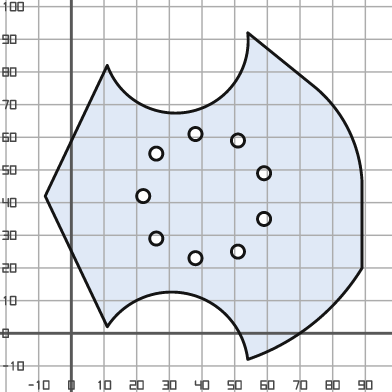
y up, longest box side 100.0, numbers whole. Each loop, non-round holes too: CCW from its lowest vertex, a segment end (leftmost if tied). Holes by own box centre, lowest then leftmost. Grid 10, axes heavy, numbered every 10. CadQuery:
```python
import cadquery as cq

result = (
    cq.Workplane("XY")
    .moveTo(54.0, -8.0)
    .threePointArc((74.0, 3.0), (89.0, 20.0))
    .lineTo(89.0, 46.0)
    .threePointArc((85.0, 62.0), (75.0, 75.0))
    .lineTo(54.0, 92.0)
    .threePointArc((37.0, 68.0), (11.0, 82.0))
    .lineTo(-8.0, 42.0)
    .lineTo(11.0, 2.0)
    .threePointArc((36.0, 12.0), (54.0, -8.0))
    .close()
    .moveTo(38.0, 23.0)
    .circle(2.0)
    .moveTo(51.0, 25.0)
    .circle(2.0)
    .moveTo(26.0, 29.0)
    .circle(2.0)
    .moveTo(59.0, 35.0)
    .circle(2.0)
    .moveTo(22.0, 42.0)
    .circle(2.0)
    .moveTo(59.0, 49.0)
    .circle(2.0)
    .moveTo(26.0, 55.0)
    .circle(2.0)
    .moveTo(51.0, 59.0)
    .circle(2.0)
    .moveTo(38.0, 61.0)
    .circle(2.0)
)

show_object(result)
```